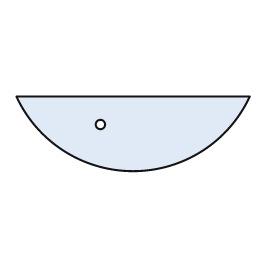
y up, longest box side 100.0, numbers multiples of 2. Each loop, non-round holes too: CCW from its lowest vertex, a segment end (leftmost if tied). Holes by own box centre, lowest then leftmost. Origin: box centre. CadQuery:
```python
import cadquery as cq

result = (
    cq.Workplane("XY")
    .moveTo(-50.0, 16.0)
    .threePointArc((0.0, -16.0), (50.0, 16.0))
    .close()
    .moveTo(-14.0, 4.0)
    .circle(2.0)
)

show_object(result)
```